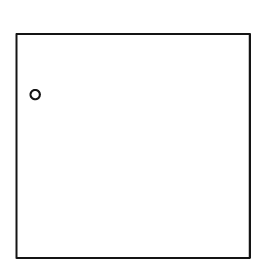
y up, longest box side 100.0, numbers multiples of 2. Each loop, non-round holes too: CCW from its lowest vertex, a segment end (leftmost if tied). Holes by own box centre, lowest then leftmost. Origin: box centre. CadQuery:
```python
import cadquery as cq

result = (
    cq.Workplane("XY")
    .moveTo(-50.0, -48.0)
    .lineTo(50.0, -48.0)
    .lineTo(50.0, 48.0)
    .lineTo(-50.0, 48.0)
    .close()
    .moveTo(-42.0, 22.0)
    .circle(2.0)
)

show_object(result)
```